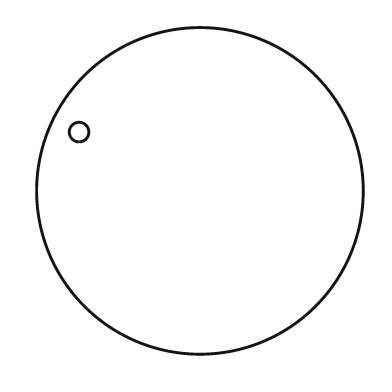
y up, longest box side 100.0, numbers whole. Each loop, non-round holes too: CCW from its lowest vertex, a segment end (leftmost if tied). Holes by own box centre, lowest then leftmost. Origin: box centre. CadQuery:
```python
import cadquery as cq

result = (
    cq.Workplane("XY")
    .moveTo(0.0, 0.0)
    .circle(50.0)
    .moveTo(-37.0, 18.0)
    .circle(3.0)
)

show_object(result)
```